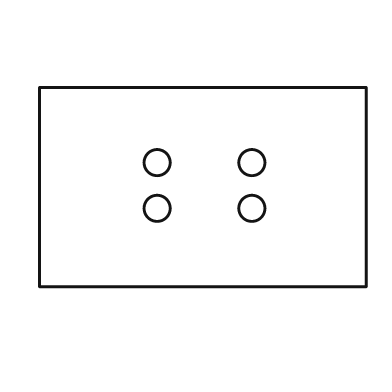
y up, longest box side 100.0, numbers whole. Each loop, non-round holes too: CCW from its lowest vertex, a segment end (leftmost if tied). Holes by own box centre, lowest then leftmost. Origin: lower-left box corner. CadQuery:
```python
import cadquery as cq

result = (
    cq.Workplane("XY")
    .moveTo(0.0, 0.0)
    .lineTo(100.0, 0.0)
    .lineTo(100.0, 61.0)
    .lineTo(0.0, 61.0)
    .close()
    .moveTo(36.0, 24.0)
    .circle(4.0)
    .moveTo(65.0, 24.0)
    .circle(4.0)
    .moveTo(36.0, 38.0)
    .circle(4.0)
    .moveTo(65.0, 38.0)
    .circle(4.0)
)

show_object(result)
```